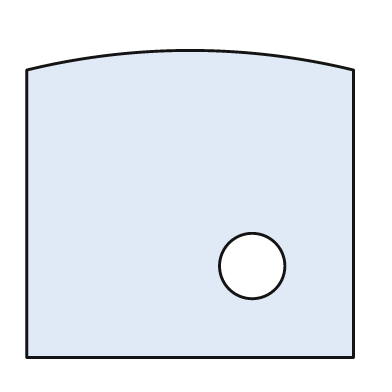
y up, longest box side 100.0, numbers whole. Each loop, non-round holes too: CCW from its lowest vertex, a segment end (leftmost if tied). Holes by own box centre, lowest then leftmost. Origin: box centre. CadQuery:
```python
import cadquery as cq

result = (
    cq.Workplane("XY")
    .moveTo(-50.0, -47.0)
    .lineTo(50.0, -47.0)
    .lineTo(50.0, 41.0)
    .threePointArc((0.0, 47.0), (-50.0, 41.0))
    .close()
    .moveTo(19.0, -19.0)
    .circle(10.0)
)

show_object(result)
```